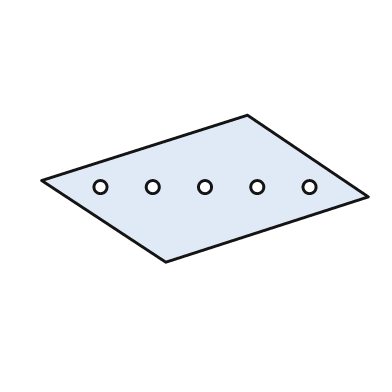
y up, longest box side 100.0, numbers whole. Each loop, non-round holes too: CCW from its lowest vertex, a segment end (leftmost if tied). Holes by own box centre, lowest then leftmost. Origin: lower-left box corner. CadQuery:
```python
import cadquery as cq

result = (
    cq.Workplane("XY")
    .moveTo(38.0, 0.0)
    .lineTo(100.0, 20.0)
    .lineTo(63.0, 45.0)
    .lineTo(0.0, 25.0)
    .close()
    .moveTo(18.0, 23.0)
    .circle(2.0)
    .moveTo(34.0, 23.0)
    .circle(2.0)
    .moveTo(50.0, 23.0)
    .circle(2.0)
    .moveTo(66.0, 23.0)
    .circle(2.0)
    .moveTo(82.0, 23.0)
    .circle(2.0)
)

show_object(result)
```